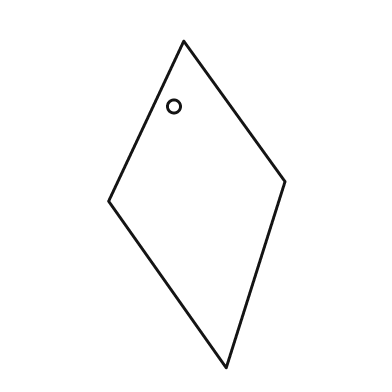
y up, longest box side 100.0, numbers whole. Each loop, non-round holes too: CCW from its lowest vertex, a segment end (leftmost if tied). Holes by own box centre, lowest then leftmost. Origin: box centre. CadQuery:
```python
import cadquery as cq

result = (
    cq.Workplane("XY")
    .moveTo(9.0, -50.0)
    .lineTo(27.0, 7.0)
    .lineTo(-4.0, 50.0)
    .lineTo(-27.0, 1.0)
    .close()
    .moveTo(-7.0, 30.0)
    .circle(2.0)
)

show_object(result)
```